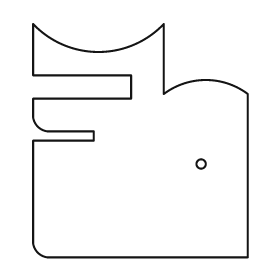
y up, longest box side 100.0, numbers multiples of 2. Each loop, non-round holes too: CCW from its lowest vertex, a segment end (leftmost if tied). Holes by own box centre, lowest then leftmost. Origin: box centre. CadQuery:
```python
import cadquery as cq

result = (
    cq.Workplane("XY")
    .moveTo(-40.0, -50.0)
    .lineTo(46.0, -50.0)
    .lineTo(46.0, 20.0)
    .threePointArc((28.0, 26.0), (10.0, 20.0))
    .lineTo(10.0, 50.0)
    .threePointArc((-18.0, 38.0), (-46.0, 50.0))
    .lineTo(-46.0, 28.0)
    .lineTo(-4.0, 28.0)
    .lineTo(-4.0, 18.0)
    .lineTo(-46.0, 18.0)
    .lineTo(-46.0, 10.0)
    .threePointArc((-44.0, 6.0), (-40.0, 4.0))
    .lineTo(-20.0, 4.0)
    .lineTo(-20.0, 0.0)
    .lineTo(-46.0, 0.0)
    .lineTo(-46.0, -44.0)
    .threePointArc((-44.0, -48.0), (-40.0, -50.0))
    .close()
    .moveTo(26.0, -10.0)
    .circle(2.0)
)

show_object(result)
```